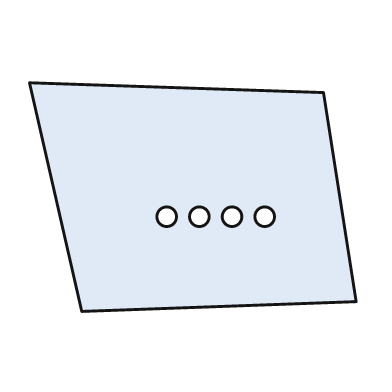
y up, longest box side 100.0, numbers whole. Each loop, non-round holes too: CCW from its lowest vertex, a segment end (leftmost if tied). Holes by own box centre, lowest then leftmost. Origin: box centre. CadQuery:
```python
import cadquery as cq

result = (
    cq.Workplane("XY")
    .moveTo(-34.0, -35.0)
    .lineTo(50.0, -32.0)
    .lineTo(40.0, 32.0)
    .lineTo(-50.0, 35.0)
    .close()
    .moveTo(-8.0, -6.0)
    .circle(3.0)
    .moveTo(2.0, -6.0)
    .circle(3.0)
    .moveTo(12.0, -6.0)
    .circle(3.0)
    .moveTo(22.0, -6.0)
    .circle(3.0)
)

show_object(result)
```